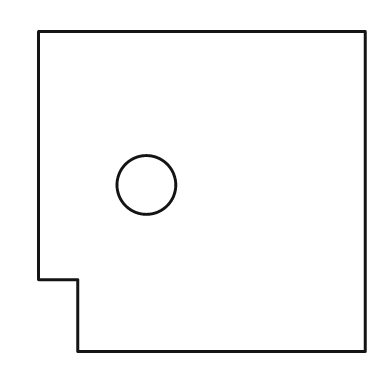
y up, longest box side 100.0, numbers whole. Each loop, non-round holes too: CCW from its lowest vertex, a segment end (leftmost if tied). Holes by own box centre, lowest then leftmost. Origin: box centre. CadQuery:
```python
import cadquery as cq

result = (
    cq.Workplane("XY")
    .moveTo(-38.0, -49.0)
    .lineTo(50.0, -49.0)
    .lineTo(50.0, 49.0)
    .lineTo(-50.0, 49.0)
    .lineTo(-50.0, -27.0)
    .lineTo(-38.0, -27.0)
    .close()
    .moveTo(-17.0, 2.0)
    .circle(9.0)
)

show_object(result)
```